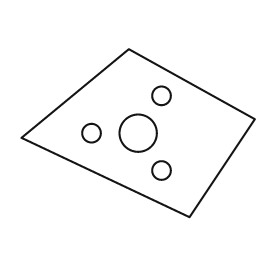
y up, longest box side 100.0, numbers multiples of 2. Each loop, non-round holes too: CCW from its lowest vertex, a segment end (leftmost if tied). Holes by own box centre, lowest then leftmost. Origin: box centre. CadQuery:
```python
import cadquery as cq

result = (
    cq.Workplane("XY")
    .moveTo(22.0, -36.0)
    .lineTo(50.0, 6.0)
    .lineTo(-4.0, 36.0)
    .lineTo(-50.0, -2.0)
    .close()
    .moveTo(10.0, -16.0)
    .circle(4.0)
    .moveTo(-20.0, 0.0)
    .circle(4.0)
    .moveTo(0.0, 0.0)
    .circle(8.0)
    .moveTo(10.0, 16.0)
    .circle(4.0)
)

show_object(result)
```